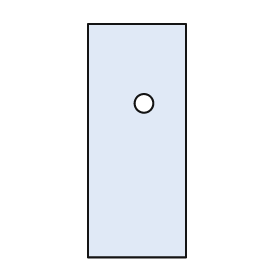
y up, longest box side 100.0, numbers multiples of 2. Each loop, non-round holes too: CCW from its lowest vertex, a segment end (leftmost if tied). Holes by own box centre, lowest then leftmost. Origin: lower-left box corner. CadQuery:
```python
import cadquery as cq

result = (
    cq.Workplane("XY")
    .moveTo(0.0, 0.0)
    .lineTo(42.0, 0.0)
    .lineTo(42.0, 100.0)
    .lineTo(0.0, 100.0)
    .close()
    .moveTo(24.0, 66.0)
    .circle(4.0)
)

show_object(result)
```